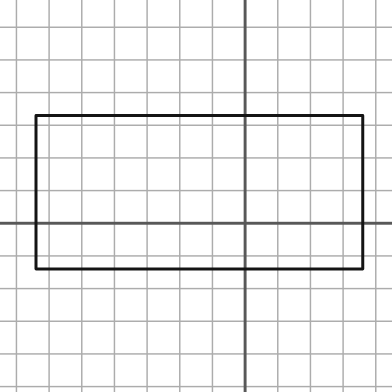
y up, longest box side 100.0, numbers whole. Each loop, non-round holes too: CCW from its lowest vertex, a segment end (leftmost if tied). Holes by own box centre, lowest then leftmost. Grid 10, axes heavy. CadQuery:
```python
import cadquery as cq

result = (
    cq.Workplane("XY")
    .moveTo(-64.0, -14.0)
    .lineTo(36.0, -14.0)
    .lineTo(36.0, 33.0)
    .lineTo(-64.0, 33.0)
    .close()
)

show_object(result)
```